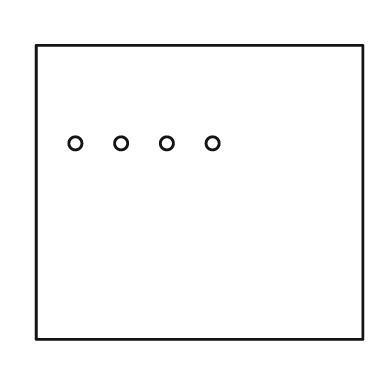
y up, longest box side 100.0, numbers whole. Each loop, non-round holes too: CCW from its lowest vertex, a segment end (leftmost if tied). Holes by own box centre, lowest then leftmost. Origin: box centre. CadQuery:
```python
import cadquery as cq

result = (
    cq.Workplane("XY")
    .moveTo(-50.0, -45.0)
    .lineTo(50.0, -45.0)
    .lineTo(50.0, 45.0)
    .lineTo(-50.0, 45.0)
    .close()
    .moveTo(-38.0, 15.0)
    .circle(2.0)
    .moveTo(-24.0, 15.0)
    .circle(2.0)
    .moveTo(-10.0, 15.0)
    .circle(2.0)
    .moveTo(4.0, 15.0)
    .circle(2.0)
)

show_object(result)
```